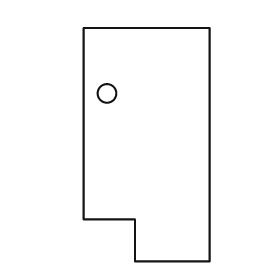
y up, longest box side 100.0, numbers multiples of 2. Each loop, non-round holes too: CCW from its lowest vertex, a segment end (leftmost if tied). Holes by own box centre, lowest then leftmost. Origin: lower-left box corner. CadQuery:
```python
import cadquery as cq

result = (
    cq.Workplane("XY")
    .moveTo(22.0, 0.0)
    .lineTo(54.0, 0.0)
    .lineTo(54.0, 100.0)
    .lineTo(0.0, 100.0)
    .lineTo(0.0, 18.0)
    .lineTo(22.0, 18.0)
    .close()
    .moveTo(10.0, 72.0)
    .circle(4.0)
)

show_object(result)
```